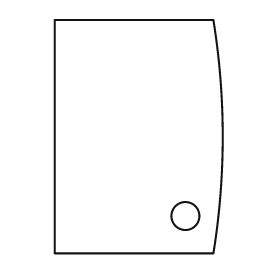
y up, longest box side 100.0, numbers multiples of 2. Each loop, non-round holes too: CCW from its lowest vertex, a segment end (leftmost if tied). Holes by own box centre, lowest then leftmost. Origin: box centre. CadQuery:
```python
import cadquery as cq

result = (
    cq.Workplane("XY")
    .moveTo(-36.0, -50.0)
    .lineTo(32.0, -50.0)
    .threePointArc((36.0, 0.0), (32.0, 50.0))
    .lineTo(-36.0, 50.0)
    .close()
    .moveTo(20.0, -34.0)
    .circle(6.0)
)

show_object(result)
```